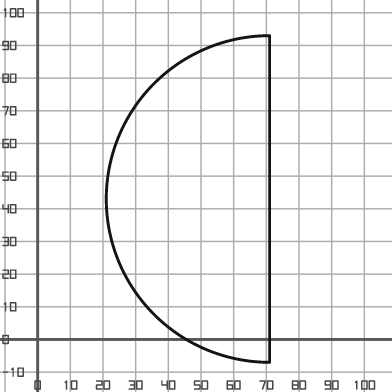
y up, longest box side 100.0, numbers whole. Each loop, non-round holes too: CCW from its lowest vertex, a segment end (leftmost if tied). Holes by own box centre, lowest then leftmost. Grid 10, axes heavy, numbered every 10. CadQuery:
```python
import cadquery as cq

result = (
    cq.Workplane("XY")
    .moveTo(71.0, -7.0)
    .lineTo(71.0, 93.0)
    .threePointArc((21.0, 43.0), (71.0, -7.0))
    .close()
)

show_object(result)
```